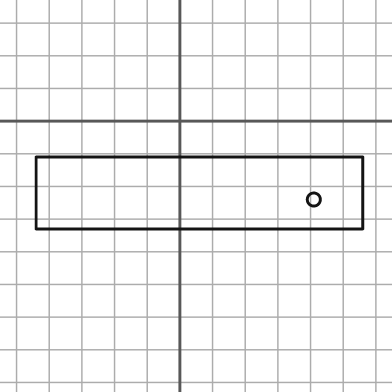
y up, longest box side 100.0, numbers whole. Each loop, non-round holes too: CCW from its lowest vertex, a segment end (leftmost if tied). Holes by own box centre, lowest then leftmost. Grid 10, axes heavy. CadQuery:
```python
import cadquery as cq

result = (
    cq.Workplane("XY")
    .moveTo(-44.0, -33.0)
    .lineTo(56.0, -33.0)
    .lineTo(56.0, -11.0)
    .lineTo(-44.0, -11.0)
    .close()
    .moveTo(41.0, -24.0)
    .circle(2.0)
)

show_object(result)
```